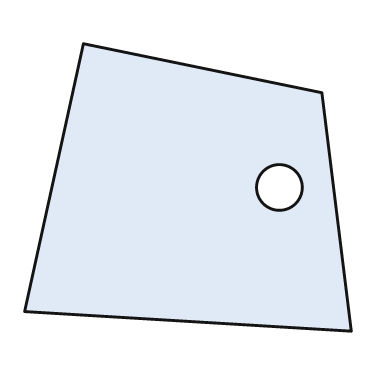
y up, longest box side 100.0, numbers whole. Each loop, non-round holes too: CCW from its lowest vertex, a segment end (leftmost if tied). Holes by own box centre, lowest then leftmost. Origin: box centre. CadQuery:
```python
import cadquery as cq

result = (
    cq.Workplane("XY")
    .moveTo(50.0, -44.0)
    .lineTo(41.0, 29.0)
    .lineTo(-32.0, 44.0)
    .lineTo(-50.0, -38.0)
    .close()
    .moveTo(28.0, 0.0)
    .circle(7.0)
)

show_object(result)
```